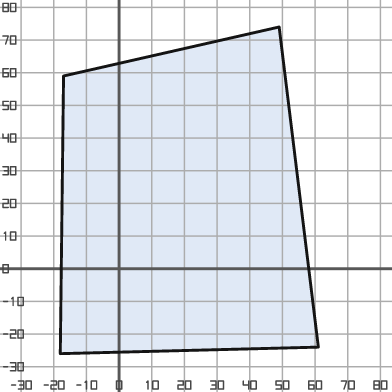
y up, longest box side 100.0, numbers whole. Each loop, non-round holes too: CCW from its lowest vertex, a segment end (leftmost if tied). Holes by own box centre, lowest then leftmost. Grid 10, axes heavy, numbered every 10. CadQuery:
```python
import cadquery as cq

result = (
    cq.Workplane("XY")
    .moveTo(-18.0, -26.0)
    .lineTo(61.0, -24.0)
    .lineTo(49.0, 74.0)
    .lineTo(-17.0, 59.0)
    .close()
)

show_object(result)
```